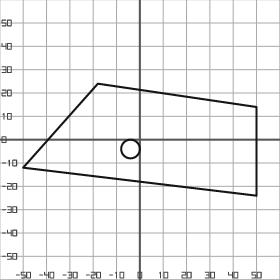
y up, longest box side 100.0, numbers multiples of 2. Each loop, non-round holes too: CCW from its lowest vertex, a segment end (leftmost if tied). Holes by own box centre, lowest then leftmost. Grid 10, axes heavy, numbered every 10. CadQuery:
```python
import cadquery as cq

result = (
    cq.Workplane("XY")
    .moveTo(50.0, -24.0)
    .lineTo(50.0, 14.0)
    .lineTo(-18.0, 24.0)
    .lineTo(-50.0, -12.0)
    .close()
    .moveTo(-4.0, -4.0)
    .circle(4.0)
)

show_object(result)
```